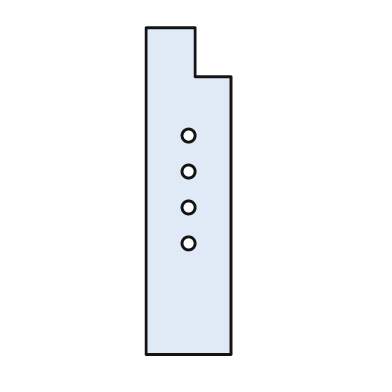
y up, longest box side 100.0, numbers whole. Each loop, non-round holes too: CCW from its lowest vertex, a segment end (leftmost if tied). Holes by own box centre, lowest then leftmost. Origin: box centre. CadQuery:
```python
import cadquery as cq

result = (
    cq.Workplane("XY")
    .moveTo(-13.0, -50.0)
    .lineTo(13.0, -50.0)
    .lineTo(13.0, 35.0)
    .lineTo(2.0, 35.0)
    .lineTo(2.0, 50.0)
    .lineTo(-13.0, 50.0)
    .close()
    .moveTo(0.0, -16.0)
    .circle(2.0)
    .moveTo(0.0, -5.0)
    .circle(2.0)
    .moveTo(0.0, 6.0)
    .circle(2.0)
    .moveTo(0.0, 17.0)
    .circle(2.0)
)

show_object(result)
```